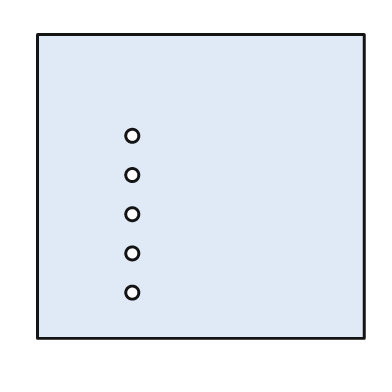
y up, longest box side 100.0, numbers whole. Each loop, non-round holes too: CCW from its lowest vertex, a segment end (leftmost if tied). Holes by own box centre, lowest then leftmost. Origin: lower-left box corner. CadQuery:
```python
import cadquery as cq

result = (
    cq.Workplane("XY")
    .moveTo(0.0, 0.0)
    .lineTo(100.0, 0.0)
    .lineTo(100.0, 93.0)
    .lineTo(0.0, 93.0)
    .close()
    .moveTo(29.0, 14.0)
    .circle(2.0)
    .moveTo(29.0, 26.0)
    .circle(2.0)
    .moveTo(29.0, 38.0)
    .circle(2.0)
    .moveTo(29.0, 50.0)
    .circle(2.0)
    .moveTo(29.0, 62.0)
    .circle(2.0)
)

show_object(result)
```